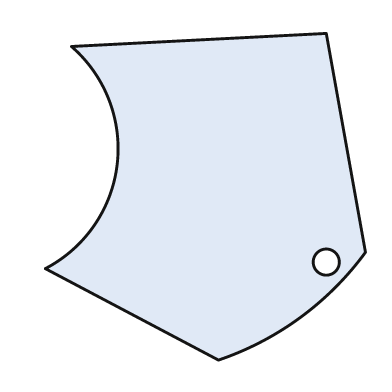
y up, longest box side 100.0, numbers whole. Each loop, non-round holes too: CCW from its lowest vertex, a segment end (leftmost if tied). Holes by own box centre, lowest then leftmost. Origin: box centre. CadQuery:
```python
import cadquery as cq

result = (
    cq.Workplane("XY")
    .moveTo(4.0, -50.0)
    .threePointArc((29.0, -37.0), (49.0, -17.0))
    .lineTo(37.0, 50.0)
    .lineTo(-41.0, 46.0)
    .threePointArc((-27.0, 10.0), (-49.0, -22.0))
    .close()
    .moveTo(37.0, -20.0)
    .circle(4.0)
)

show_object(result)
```